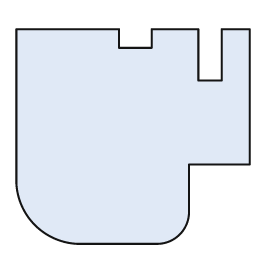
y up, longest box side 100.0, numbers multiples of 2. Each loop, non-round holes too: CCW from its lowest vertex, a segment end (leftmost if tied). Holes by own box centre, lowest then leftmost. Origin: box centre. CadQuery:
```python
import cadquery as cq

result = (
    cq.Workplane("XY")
    .moveTo(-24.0, -46.0)
    .lineTo(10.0, -46.0)
    .threePointArc((20.0, -42.0), (24.0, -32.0))
    .lineTo(24.0, -12.0)
    .lineTo(50.0, -12.0)
    .lineTo(50.0, 46.0)
    .lineTo(38.0, 46.0)
    .lineTo(38.0, 24.0)
    .lineTo(28.0, 24.0)
    .lineTo(28.0, 46.0)
    .lineTo(8.0, 46.0)
    .lineTo(8.0, 38.0)
    .lineTo(-6.0, 38.0)
    .lineTo(-6.0, 46.0)
    .lineTo(-50.0, 46.0)
    .lineTo(-50.0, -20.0)
    .threePointArc((-42.0, -38.0), (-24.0, -46.0))
    .close()
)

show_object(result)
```